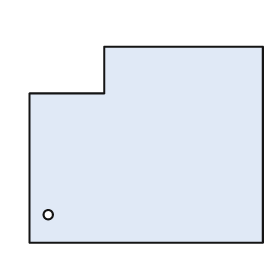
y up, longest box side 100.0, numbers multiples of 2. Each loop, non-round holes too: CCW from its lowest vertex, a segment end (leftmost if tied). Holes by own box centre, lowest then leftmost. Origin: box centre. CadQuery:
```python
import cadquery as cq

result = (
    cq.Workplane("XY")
    .moveTo(-50.0, -42.0)
    .lineTo(50.0, -42.0)
    .lineTo(50.0, 42.0)
    .lineTo(-18.0, 42.0)
    .lineTo(-18.0, 22.0)
    .lineTo(-50.0, 22.0)
    .close()
    .moveTo(-42.0, -30.0)
    .circle(2.0)
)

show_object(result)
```